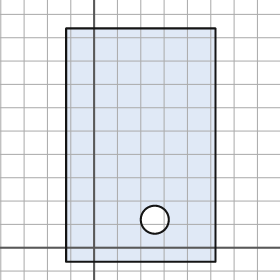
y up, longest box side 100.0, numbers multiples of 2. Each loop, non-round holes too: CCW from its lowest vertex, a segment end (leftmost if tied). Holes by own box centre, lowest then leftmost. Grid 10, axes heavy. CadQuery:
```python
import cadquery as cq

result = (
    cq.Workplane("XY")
    .moveTo(-12.0, -6.0)
    .lineTo(52.0, -6.0)
    .lineTo(52.0, 94.0)
    .lineTo(-12.0, 94.0)
    .close()
    .moveTo(26.0, 12.0)
    .circle(6.0)
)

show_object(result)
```